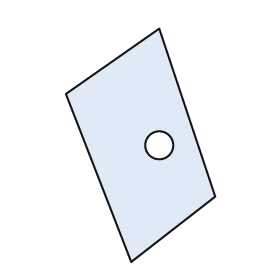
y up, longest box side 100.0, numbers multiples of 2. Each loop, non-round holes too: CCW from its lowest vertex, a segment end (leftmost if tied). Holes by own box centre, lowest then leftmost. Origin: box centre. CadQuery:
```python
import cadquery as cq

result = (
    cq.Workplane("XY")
    .moveTo(-4.0, -50.0)
    .lineTo(32.0, -22.0)
    .lineTo(8.0, 50.0)
    .lineTo(-32.0, 22.0)
    .close()
    .moveTo(8.0, 0.0)
    .circle(6.0)
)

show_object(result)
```